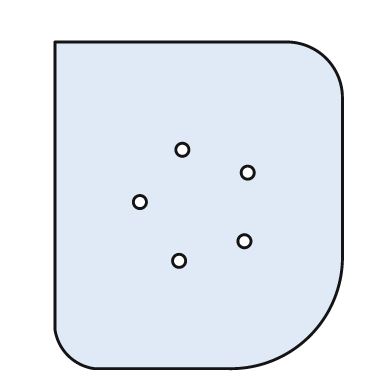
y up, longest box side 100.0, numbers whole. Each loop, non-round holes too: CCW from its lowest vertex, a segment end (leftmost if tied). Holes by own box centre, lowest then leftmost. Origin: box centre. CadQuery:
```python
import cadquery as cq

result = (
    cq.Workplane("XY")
    .moveTo(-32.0, -50.0)
    .lineTo(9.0, -50.0)
    .threePointArc((34.0, -40.0), (44.0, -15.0))
    .lineTo(44.0, 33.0)
    .threePointArc((39.0, 45.0), (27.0, 50.0))
    .lineTo(-44.0, 50.0)
    .lineTo(-44.0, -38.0)
    .threePointArc((-40.0, -46.0), (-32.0, -50.0))
    .close()
    .moveTo(-6.0, -17.0)
    .circle(2.0)
    .moveTo(14.0, -11.0)
    .circle(2.0)
    .moveTo(-18.0, 1.0)
    .circle(2.0)
    .moveTo(15.0, 10.0)
    .circle(2.0)
    .moveTo(-5.0, 17.0)
    .circle(2.0)
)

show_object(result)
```